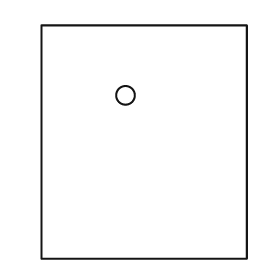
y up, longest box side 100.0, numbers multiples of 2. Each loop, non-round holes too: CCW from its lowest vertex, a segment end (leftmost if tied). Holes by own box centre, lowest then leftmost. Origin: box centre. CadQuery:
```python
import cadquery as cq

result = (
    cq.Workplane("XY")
    .moveTo(-44.0, -50.0)
    .lineTo(44.0, -50.0)
    .lineTo(44.0, 50.0)
    .lineTo(-44.0, 50.0)
    .close()
    .moveTo(-8.0, 20.0)
    .circle(4.0)
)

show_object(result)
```